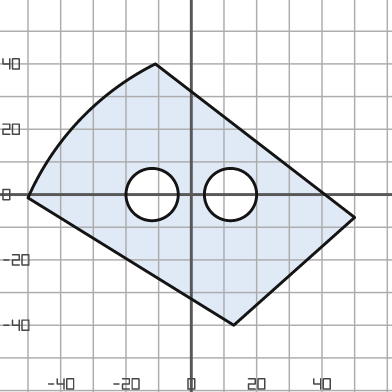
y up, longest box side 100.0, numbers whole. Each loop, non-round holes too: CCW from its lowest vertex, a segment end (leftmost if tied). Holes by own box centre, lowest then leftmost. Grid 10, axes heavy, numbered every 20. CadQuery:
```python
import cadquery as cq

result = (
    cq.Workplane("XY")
    .moveTo(13.0, -40.0)
    .lineTo(50.0, -7.0)
    .lineTo(-11.0, 40.0)
    .threePointArc((-34.0, 23.0), (-50.0, -1.0))
    .close()
    .moveTo(-12.0, 0.0)
    .circle(8.0)
    .moveTo(12.0, 0.0)
    .circle(8.0)
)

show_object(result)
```